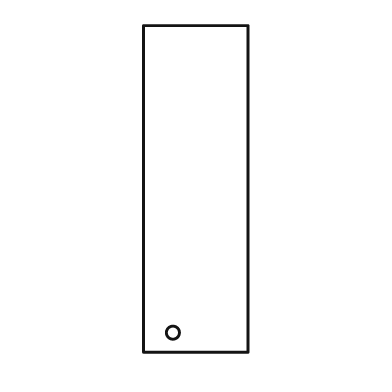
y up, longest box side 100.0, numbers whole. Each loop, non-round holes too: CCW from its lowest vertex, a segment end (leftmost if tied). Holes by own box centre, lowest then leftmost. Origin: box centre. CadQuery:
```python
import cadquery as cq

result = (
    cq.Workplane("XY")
    .moveTo(-16.0, -50.0)
    .lineTo(16.0, -50.0)
    .lineTo(16.0, 50.0)
    .lineTo(-16.0, 50.0)
    .close()
    .moveTo(-7.0, -44.0)
    .circle(2.0)
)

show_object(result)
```